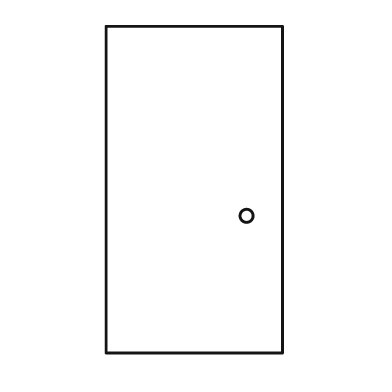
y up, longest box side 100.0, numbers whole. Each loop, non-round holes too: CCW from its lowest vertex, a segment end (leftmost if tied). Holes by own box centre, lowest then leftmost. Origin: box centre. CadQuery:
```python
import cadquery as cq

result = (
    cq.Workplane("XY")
    .moveTo(-27.0, -50.0)
    .lineTo(27.0, -50.0)
    .lineTo(27.0, 50.0)
    .lineTo(-27.0, 50.0)
    .close()
    .moveTo(16.0, -8.0)
    .circle(2.0)
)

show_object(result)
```